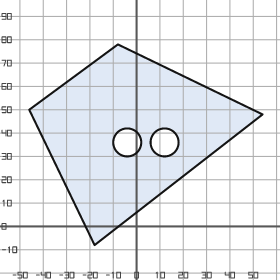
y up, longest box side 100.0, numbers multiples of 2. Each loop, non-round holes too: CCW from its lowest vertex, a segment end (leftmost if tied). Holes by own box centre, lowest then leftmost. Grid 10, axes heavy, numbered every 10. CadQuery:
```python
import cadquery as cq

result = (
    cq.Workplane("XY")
    .moveTo(-18.0, -8.0)
    .lineTo(54.0, 48.0)
    .lineTo(-8.0, 78.0)
    .lineTo(-46.0, 50.0)
    .close()
    .moveTo(-4.0, 36.0)
    .circle(6.0)
    .moveTo(12.0, 36.0)
    .circle(6.0)
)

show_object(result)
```